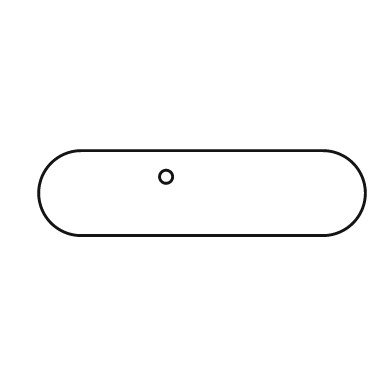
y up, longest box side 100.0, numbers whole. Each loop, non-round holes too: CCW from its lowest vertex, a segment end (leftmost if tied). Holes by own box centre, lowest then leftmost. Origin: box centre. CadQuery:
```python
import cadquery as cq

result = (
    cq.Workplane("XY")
    .moveTo(-37.0, -13.0)
    .lineTo(37.0, -13.0)
    .threePointArc((50.0, 0.0), (37.0, 13.0))
    .lineTo(-37.0, 13.0)
    .threePointArc((-50.0, 0.0), (-37.0, -13.0))
    .close()
    .moveTo(-11.0, 5.0)
    .circle(2.0)
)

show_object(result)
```